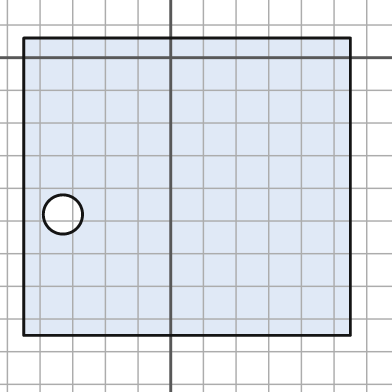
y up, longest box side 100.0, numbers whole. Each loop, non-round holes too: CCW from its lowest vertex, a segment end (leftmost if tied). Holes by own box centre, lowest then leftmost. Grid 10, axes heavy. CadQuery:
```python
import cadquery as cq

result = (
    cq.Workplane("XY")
    .moveTo(-45.0, -85.0)
    .lineTo(55.0, -85.0)
    .lineTo(55.0, 6.0)
    .lineTo(-45.0, 6.0)
    .close()
    .moveTo(-33.0, -48.0)
    .circle(6.0)
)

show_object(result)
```